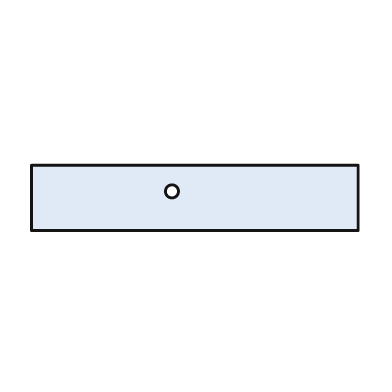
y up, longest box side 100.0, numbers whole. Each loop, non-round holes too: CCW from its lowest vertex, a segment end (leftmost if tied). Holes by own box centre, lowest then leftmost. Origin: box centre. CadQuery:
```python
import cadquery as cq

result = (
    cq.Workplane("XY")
    .moveTo(-50.0, -10.0)
    .lineTo(50.0, -10.0)
    .lineTo(50.0, 10.0)
    .lineTo(-50.0, 10.0)
    .close()
    .moveTo(-7.0, 2.0)
    .circle(2.0)
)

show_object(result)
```